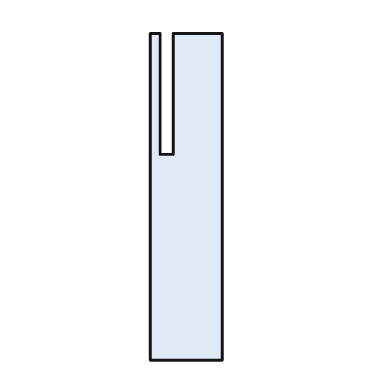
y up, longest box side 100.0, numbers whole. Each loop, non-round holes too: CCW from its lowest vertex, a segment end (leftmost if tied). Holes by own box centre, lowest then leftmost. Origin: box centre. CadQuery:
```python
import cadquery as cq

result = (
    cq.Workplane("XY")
    .moveTo(-11.0, -50.0)
    .lineTo(11.0, -50.0)
    .lineTo(11.0, 50.0)
    .lineTo(-4.0, 50.0)
    .lineTo(-4.0, 13.0)
    .lineTo(-8.0, 13.0)
    .lineTo(-8.0, 50.0)
    .lineTo(-11.0, 50.0)
    .close()
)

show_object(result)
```